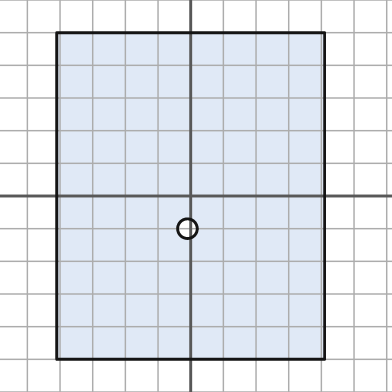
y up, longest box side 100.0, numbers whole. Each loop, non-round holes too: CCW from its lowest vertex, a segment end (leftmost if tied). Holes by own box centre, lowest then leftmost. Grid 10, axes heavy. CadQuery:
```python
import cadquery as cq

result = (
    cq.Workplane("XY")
    .moveTo(-41.0, -50.0)
    .lineTo(41.0, -50.0)
    .lineTo(41.0, 50.0)
    .lineTo(-41.0, 50.0)
    .close()
    .moveTo(-1.0, -10.0)
    .circle(3.0)
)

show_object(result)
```